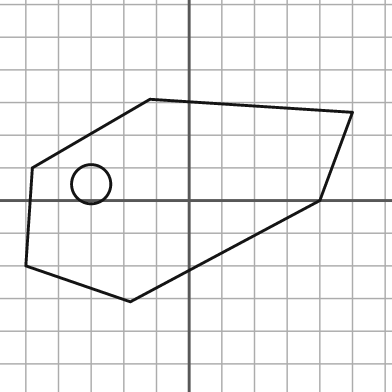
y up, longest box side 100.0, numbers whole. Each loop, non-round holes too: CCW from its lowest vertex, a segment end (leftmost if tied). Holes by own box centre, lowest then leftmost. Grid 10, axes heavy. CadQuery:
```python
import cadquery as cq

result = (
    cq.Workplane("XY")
    .moveTo(-18.0, -31.0)
    .lineTo(40.0, 0.0)
    .lineTo(50.0, 27.0)
    .lineTo(-12.0, 31.0)
    .lineTo(-48.0, 10.0)
    .lineTo(-50.0, -20.0)
    .close()
    .moveTo(-30.0, 5.0)
    .circle(6.0)
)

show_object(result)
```